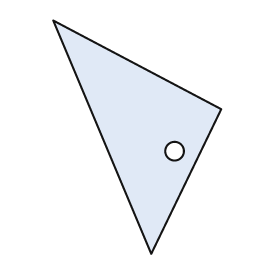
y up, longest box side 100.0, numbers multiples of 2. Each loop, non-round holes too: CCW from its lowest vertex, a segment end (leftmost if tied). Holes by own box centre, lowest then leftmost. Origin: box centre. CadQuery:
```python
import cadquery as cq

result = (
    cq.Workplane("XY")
    .moveTo(6.0, -50.0)
    .lineTo(36.0, 12.0)
    .lineTo(-36.0, 50.0)
    .close()
    .moveTo(16.0, -6.0)
    .circle(4.0)
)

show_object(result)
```